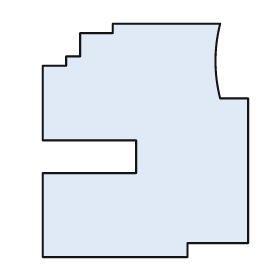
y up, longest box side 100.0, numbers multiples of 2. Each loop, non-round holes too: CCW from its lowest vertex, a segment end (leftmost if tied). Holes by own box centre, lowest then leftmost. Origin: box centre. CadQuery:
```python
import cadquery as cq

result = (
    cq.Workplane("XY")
    .moveTo(-44.0, -50.0)
    .lineTo(18.0, -50.0)
    .lineTo(18.0, -44.0)
    .lineTo(44.0, -44.0)
    .lineTo(44.0, 18.0)
    .lineTo(32.0, 18.0)
    .threePointArc((30.0, 34.0), (32.0, 50.0))
    .lineTo(-14.0, 50.0)
    .lineTo(-14.0, 46.0)
    .lineTo(-28.0, 46.0)
    .lineTo(-28.0, 36.0)
    .lineTo(-34.0, 36.0)
    .lineTo(-34.0, 32.0)
    .lineTo(-44.0, 32.0)
    .lineTo(-44.0, 0.0)
    .lineTo(-4.0, 0.0)
    .lineTo(-4.0, -14.0)
    .lineTo(-44.0, -14.0)
    .close()
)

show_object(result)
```